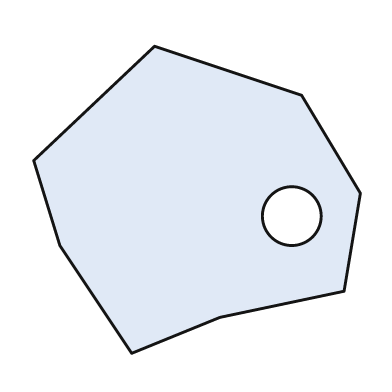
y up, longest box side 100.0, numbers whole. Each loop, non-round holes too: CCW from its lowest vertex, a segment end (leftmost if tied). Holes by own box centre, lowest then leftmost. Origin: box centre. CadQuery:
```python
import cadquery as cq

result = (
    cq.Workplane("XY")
    .moveTo(-20.0, -47.0)
    .lineTo(7.0, -36.0)
    .lineTo(45.0, -28.0)
    .lineTo(50.0, 2.0)
    .lineTo(32.0, 32.0)
    .lineTo(-13.0, 47.0)
    .lineTo(-50.0, 12.0)
    .lineTo(-42.0, -14.0)
    .close()
    .moveTo(29.0, -5.0)
    .circle(9.0)
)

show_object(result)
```